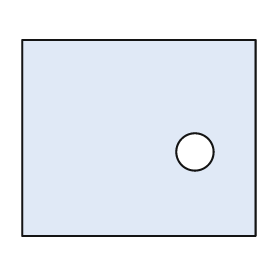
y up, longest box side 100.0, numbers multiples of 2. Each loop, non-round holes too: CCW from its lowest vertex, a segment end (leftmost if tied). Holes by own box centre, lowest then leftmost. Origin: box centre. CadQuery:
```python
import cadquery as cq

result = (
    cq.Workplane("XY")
    .moveTo(-50.0, -42.0)
    .lineTo(50.0, -42.0)
    .lineTo(50.0, 42.0)
    .lineTo(-50.0, 42.0)
    .close()
    .moveTo(24.0, -6.0)
    .circle(8.0)
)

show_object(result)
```